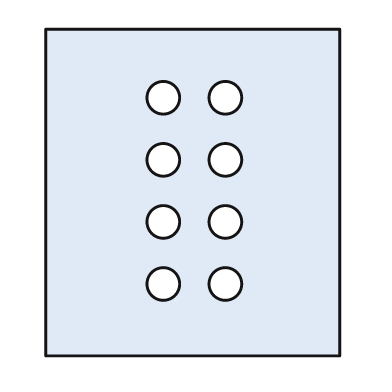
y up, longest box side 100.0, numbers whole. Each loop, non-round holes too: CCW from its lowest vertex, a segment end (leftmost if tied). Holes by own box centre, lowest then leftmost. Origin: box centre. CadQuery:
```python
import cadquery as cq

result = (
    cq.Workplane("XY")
    .moveTo(-45.0, -50.0)
    .lineTo(45.0, -50.0)
    .lineTo(45.0, 50.0)
    .lineTo(-45.0, 50.0)
    .close()
    .moveTo(-9.0, -28.0)
    .circle(5.0)
    .moveTo(10.0, -28.0)
    .circle(5.0)
    .moveTo(-9.0, -9.0)
    .circle(5.0)
    .moveTo(10.0, -9.0)
    .circle(5.0)
    .moveTo(-9.0, 10.0)
    .circle(5.0)
    .moveTo(10.0, 10.0)
    .circle(5.0)
    .moveTo(-9.0, 29.0)
    .circle(5.0)
    .moveTo(10.0, 29.0)
    .circle(5.0)
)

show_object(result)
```